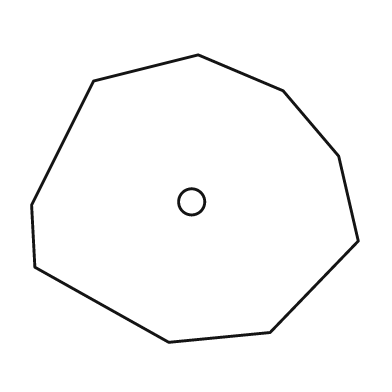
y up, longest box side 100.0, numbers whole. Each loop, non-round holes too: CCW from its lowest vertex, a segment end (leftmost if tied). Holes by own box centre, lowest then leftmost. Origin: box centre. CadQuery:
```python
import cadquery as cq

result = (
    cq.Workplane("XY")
    .moveTo(-8.0, -44.0)
    .lineTo(23.0, -41.0)
    .lineTo(50.0, -13.0)
    .lineTo(44.0, 13.0)
    .lineTo(27.0, 33.0)
    .lineTo(1.0, 44.0)
    .lineTo(-31.0, 36.0)
    .lineTo(-50.0, -2.0)
    .lineTo(-49.0, -21.0)
    .close()
    .moveTo(-1.0, -1.0)
    .circle(4.0)
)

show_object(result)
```